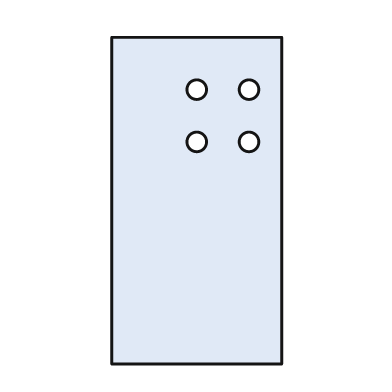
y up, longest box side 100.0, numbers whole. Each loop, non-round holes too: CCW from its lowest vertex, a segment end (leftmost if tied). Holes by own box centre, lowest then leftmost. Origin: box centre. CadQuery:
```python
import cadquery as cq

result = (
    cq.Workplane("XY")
    .moveTo(-26.0, -50.0)
    .lineTo(26.0, -50.0)
    .lineTo(26.0, 50.0)
    .lineTo(-26.0, 50.0)
    .close()
    .moveTo(0.0, 18.0)
    .circle(3.0)
    .moveTo(16.0, 18.0)
    .circle(3.0)
    .moveTo(0.0, 34.0)
    .circle(3.0)
    .moveTo(16.0, 34.0)
    .circle(3.0)
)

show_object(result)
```